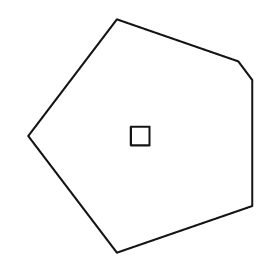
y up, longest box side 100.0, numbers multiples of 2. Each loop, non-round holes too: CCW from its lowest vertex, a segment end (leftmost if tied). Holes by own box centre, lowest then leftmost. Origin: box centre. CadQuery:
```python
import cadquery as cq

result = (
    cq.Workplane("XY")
    .moveTo(-10.0, -50.0)
    .lineTo(48.0, -30.0)
    .lineTo(48.0, 24.0)
    .lineTo(42.0, 32.0)
    .lineTo(-10.0, 50.0)
    .lineTo(-48.0, 0.0)
    .close()
    .moveTo(-4.0, -4.0)
    .lineTo(4.0, -4.0)
    .lineTo(4.0, 4.0)
    .lineTo(-4.0, 4.0)
    .close()
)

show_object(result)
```